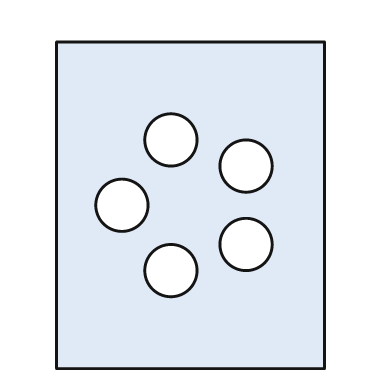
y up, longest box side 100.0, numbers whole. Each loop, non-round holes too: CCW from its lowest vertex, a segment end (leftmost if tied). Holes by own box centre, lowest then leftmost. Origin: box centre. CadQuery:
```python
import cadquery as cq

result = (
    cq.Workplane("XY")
    .moveTo(-41.0, -50.0)
    .lineTo(41.0, -50.0)
    .lineTo(41.0, 50.0)
    .lineTo(-41.0, 50.0)
    .close()
    .moveTo(-6.0, -20.0)
    .circle(8.0)
    .moveTo(17.0, -12.0)
    .circle(8.0)
    .moveTo(-21.0, 0.0)
    .circle(8.0)
    .moveTo(17.0, 12.0)
    .circle(8.0)
    .moveTo(-6.0, 20.0)
    .circle(8.0)
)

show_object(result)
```